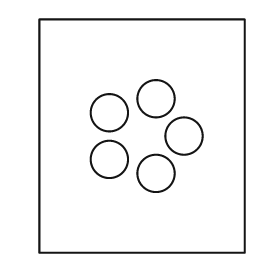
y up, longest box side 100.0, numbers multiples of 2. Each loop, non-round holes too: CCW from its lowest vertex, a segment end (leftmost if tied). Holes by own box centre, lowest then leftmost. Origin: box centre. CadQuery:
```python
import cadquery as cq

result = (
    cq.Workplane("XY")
    .moveTo(-44.0, -50.0)
    .lineTo(44.0, -50.0)
    .lineTo(44.0, 50.0)
    .lineTo(-44.0, 50.0)
    .close()
    .moveTo(6.0, -16.0)
    .circle(8.0)
    .moveTo(-14.0, -10.0)
    .circle(8.0)
    .moveTo(18.0, 0.0)
    .circle(8.0)
    .moveTo(-14.0, 10.0)
    .circle(8.0)
    .moveTo(6.0, 16.0)
    .circle(8.0)
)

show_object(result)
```